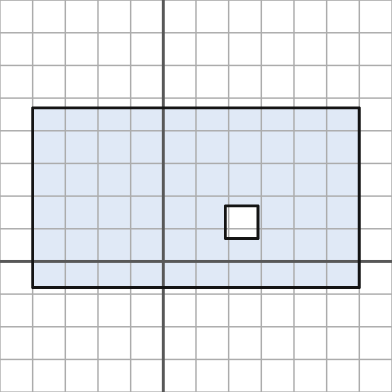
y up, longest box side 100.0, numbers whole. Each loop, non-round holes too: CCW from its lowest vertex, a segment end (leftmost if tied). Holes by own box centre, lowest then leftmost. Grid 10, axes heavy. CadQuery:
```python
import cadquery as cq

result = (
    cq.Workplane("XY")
    .moveTo(-40.0, -8.0)
    .lineTo(60.0, -8.0)
    .lineTo(60.0, 47.0)
    .lineTo(-40.0, 47.0)
    .close()
    .moveTo(19.0, 7.0)
    .lineTo(29.0, 7.0)
    .lineTo(29.0, 17.0)
    .lineTo(19.0, 17.0)
    .close()
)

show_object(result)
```